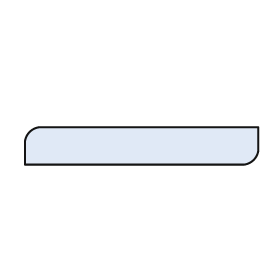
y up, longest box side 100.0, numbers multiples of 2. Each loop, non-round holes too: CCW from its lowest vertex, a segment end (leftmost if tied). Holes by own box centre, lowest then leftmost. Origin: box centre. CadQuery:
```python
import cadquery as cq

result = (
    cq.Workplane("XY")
    .moveTo(-50.0, -8.0)
    .lineTo(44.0, -8.0)
    .threePointArc((48.0, -6.0), (50.0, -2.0))
    .lineTo(50.0, 8.0)
    .lineTo(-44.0, 8.0)
    .threePointArc((-48.0, 6.0), (-50.0, 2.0))
    .close()
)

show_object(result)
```